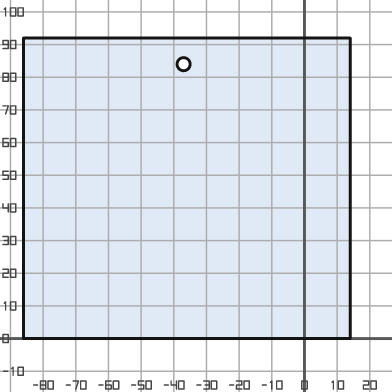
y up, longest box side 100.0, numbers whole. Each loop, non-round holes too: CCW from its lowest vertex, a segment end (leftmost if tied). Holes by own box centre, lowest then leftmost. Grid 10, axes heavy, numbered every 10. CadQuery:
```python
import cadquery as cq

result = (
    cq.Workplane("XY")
    .moveTo(-86.0, 0.0)
    .lineTo(14.0, 0.0)
    .lineTo(14.0, 92.0)
    .lineTo(-86.0, 92.0)
    .close()
    .moveTo(-37.0, 84.0)
    .circle(2.0)
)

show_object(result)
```